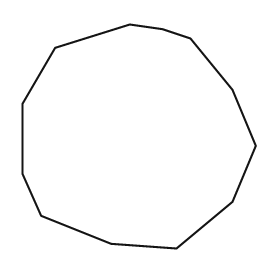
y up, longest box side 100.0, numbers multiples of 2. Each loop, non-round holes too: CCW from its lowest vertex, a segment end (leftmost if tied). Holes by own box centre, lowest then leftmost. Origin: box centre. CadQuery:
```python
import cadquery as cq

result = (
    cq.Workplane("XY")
    .moveTo(16.0, -48.0)
    .lineTo(40.0, -28.0)
    .lineTo(50.0, -4.0)
    .lineTo(40.0, 20.0)
    .lineTo(22.0, 42.0)
    .lineTo(10.0, 46.0)
    .lineTo(-4.0, 48.0)
    .lineTo(-36.0, 38.0)
    .lineTo(-50.0, 14.0)
    .lineTo(-50.0, -16.0)
    .lineTo(-42.0, -34.0)
    .lineTo(-12.0, -46.0)
    .close()
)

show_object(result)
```